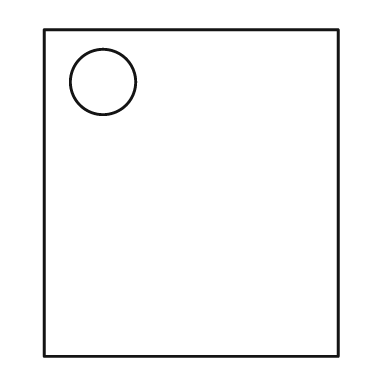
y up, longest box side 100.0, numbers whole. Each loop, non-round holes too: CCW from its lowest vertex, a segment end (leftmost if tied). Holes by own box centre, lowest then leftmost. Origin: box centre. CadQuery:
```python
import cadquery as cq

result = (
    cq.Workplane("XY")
    .moveTo(-45.0, -50.0)
    .lineTo(45.0, -50.0)
    .lineTo(45.0, 50.0)
    .lineTo(-45.0, 50.0)
    .close()
    .moveTo(-27.0, 34.0)
    .circle(10.0)
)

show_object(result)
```